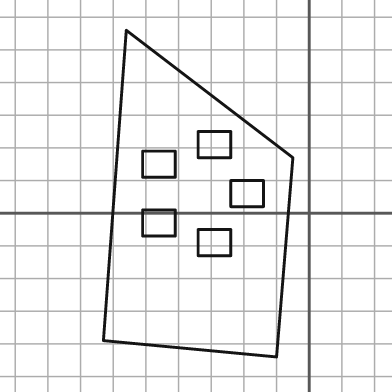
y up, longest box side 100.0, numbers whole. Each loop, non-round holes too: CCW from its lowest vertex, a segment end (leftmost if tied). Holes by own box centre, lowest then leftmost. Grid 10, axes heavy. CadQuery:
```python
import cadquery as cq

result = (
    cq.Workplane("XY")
    .moveTo(-10.0, -44.0)
    .lineTo(-5.0, 17.0)
    .lineTo(-56.0, 56.0)
    .lineTo(-63.0, -39.0)
    .close()
    .moveTo(-34.0, -13.0)
    .lineTo(-24.0, -13.0)
    .lineTo(-24.0, -5.0)
    .lineTo(-34.0, -5.0)
    .close()
    .moveTo(-51.0, -7.0)
    .lineTo(-41.0, -7.0)
    .lineTo(-41.0, 1.0)
    .lineTo(-51.0, 1.0)
    .close()
    .moveTo(-24.0, 2.0)
    .lineTo(-14.0, 2.0)
    .lineTo(-14.0, 10.0)
    .lineTo(-24.0, 10.0)
    .close()
    .moveTo(-51.0, 11.0)
    .lineTo(-41.0, 11.0)
    .lineTo(-41.0, 19.0)
    .lineTo(-51.0, 19.0)
    .close()
    .moveTo(-34.0, 17.0)
    .lineTo(-24.0, 17.0)
    .lineTo(-24.0, 25.0)
    .lineTo(-34.0, 25.0)
    .close()
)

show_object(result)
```